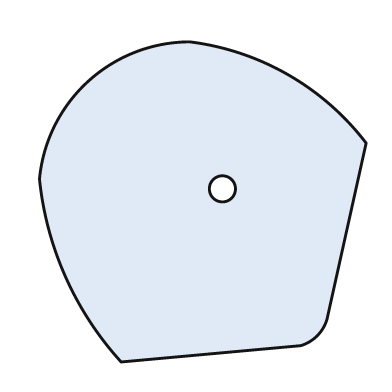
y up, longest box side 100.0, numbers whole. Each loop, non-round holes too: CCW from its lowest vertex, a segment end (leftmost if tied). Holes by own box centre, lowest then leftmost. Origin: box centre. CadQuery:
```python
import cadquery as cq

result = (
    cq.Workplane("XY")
    .moveTo(-25.0, -49.0)
    .lineTo(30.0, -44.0)
    .threePointArc((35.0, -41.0), (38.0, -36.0))
    .lineTo(50.0, 18.0)
    .threePointArc((26.0, 39.0), (-4.0, 49.0))
    .threePointArc((-35.0, 37.0), (-50.0, 7.0))
    .threePointArc((-42.0, -23.0), (-25.0, -49.0))
    .close()
    .moveTo(6.0, 4.0)
    .circle(4.0)
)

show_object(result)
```